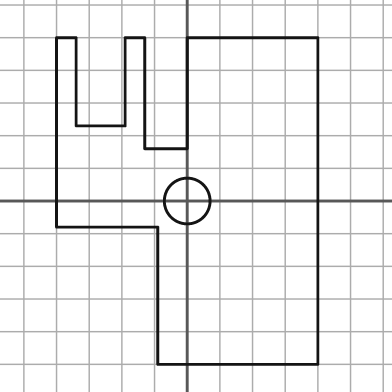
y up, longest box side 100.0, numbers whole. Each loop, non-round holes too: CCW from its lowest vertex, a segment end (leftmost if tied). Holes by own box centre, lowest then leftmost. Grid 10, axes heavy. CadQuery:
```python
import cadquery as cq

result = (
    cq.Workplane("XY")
    .moveTo(-9.0, -50.0)
    .lineTo(40.0, -50.0)
    .lineTo(40.0, 50.0)
    .lineTo(0.0, 50.0)
    .lineTo(0.0, 16.0)
    .lineTo(-13.0, 16.0)
    .lineTo(-13.0, 50.0)
    .lineTo(-19.0, 50.0)
    .lineTo(-19.0, 23.0)
    .lineTo(-34.0, 23.0)
    .lineTo(-34.0, 50.0)
    .lineTo(-40.0, 50.0)
    .lineTo(-40.0, -8.0)
    .lineTo(-9.0, -8.0)
    .close()
    .moveTo(0.0, 0.0)
    .circle(7.0)
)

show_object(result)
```